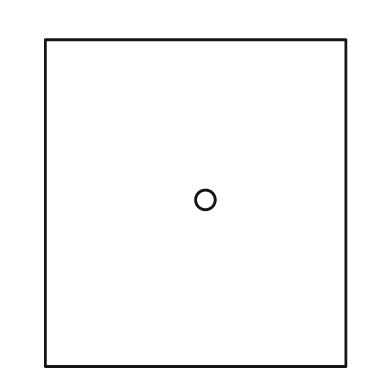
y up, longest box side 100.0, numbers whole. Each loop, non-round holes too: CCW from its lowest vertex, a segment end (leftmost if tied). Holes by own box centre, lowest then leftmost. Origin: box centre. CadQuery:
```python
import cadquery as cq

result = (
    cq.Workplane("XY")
    .moveTo(-46.0, -50.0)
    .lineTo(46.0, -50.0)
    .lineTo(46.0, 50.0)
    .lineTo(-46.0, 50.0)
    .close()
    .moveTo(3.0, 1.0)
    .circle(3.0)
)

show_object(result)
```